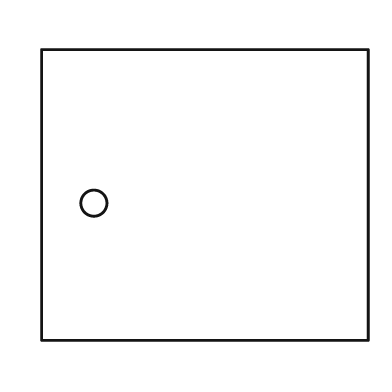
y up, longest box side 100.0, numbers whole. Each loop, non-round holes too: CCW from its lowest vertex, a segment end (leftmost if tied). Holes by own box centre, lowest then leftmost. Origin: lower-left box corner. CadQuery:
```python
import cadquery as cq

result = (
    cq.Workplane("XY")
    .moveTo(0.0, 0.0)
    .lineTo(100.0, 0.0)
    .lineTo(100.0, 89.0)
    .lineTo(0.0, 89.0)
    .close()
    .moveTo(16.0, 42.0)
    .circle(4.0)
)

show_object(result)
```